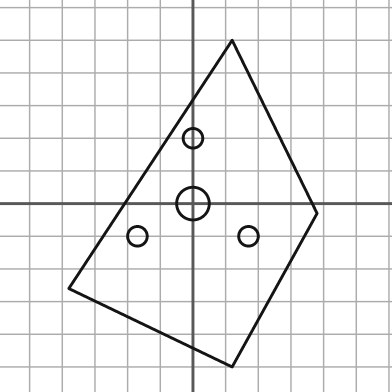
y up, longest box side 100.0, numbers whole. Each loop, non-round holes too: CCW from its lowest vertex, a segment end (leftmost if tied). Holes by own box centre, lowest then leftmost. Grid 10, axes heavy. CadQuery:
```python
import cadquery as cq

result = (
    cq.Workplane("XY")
    .moveTo(12.0, -50.0)
    .lineTo(38.0, -3.0)
    .lineTo(12.0, 50.0)
    .lineTo(-38.0, -26.0)
    .close()
    .moveTo(-17.0, -10.0)
    .circle(3.0)
    .moveTo(17.0, -10.0)
    .circle(3.0)
    .moveTo(0.0, 0.0)
    .circle(5.0)
    .moveTo(0.0, 20.0)
    .circle(3.0)
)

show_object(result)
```